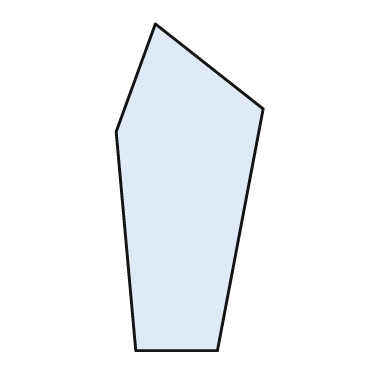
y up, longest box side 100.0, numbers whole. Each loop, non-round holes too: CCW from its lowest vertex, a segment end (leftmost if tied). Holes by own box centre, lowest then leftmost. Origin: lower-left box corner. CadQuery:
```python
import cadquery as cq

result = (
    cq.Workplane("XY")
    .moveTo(6.0, 0.0)
    .lineTo(31.0, 0.0)
    .lineTo(45.0, 74.0)
    .lineTo(12.0, 100.0)
    .lineTo(0.0, 67.0)
    .close()
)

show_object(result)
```